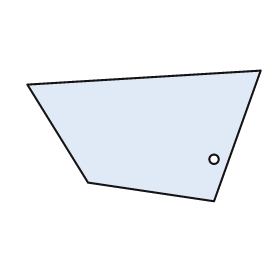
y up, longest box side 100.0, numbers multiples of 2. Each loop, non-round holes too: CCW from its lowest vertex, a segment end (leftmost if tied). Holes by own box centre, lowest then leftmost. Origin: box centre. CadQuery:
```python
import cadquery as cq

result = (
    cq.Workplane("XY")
    .moveTo(30.0, -28.0)
    .lineTo(50.0, 28.0)
    .lineTo(-50.0, 22.0)
    .lineTo(-24.0, -20.0)
    .close()
    .moveTo(30.0, -10.0)
    .circle(2.0)
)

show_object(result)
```